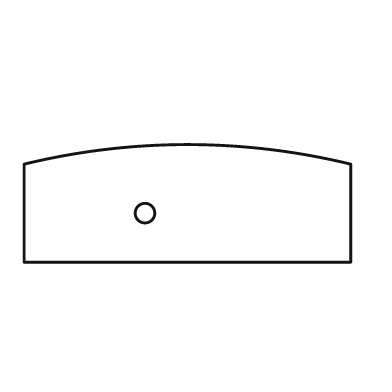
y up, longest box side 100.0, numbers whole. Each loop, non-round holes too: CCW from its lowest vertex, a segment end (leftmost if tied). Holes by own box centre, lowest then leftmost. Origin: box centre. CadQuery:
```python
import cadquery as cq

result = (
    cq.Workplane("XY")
    .moveTo(-50.0, -18.0)
    .lineTo(50.0, -18.0)
    .lineTo(50.0, 12.0)
    .threePointArc((0.0, 18.0), (-50.0, 12.0))
    .close()
    .moveTo(-13.0, -3.0)
    .circle(3.0)
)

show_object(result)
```